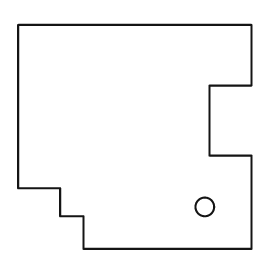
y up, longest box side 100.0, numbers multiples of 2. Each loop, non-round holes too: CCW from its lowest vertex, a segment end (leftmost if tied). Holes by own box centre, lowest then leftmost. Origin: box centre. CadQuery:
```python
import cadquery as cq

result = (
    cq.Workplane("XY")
    .moveTo(-22.0, -48.0)
    .lineTo(50.0, -48.0)
    .lineTo(50.0, -8.0)
    .lineTo(32.0, -8.0)
    .lineTo(32.0, 22.0)
    .lineTo(50.0, 22.0)
    .lineTo(50.0, 48.0)
    .lineTo(-50.0, 48.0)
    .lineTo(-50.0, -22.0)
    .lineTo(-32.0, -22.0)
    .lineTo(-32.0, -34.0)
    .lineTo(-22.0, -34.0)
    .close()
    .moveTo(30.0, -30.0)
    .circle(4.0)
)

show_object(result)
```